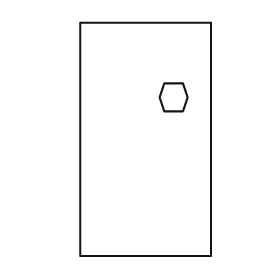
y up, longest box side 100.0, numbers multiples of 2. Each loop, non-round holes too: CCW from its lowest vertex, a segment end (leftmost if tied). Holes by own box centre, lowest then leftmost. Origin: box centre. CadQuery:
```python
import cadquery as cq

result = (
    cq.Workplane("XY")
    .moveTo(-28.0, -50.0)
    .lineTo(28.0, -50.0)
    .lineTo(28.0, 50.0)
    .lineTo(-28.0, 50.0)
    .close()
    .moveTo(8.0, 12.0)
    .lineTo(16.0, 12.0)
    .lineTo(18.0, 18.0)
    .lineTo(16.0, 24.0)
    .lineTo(8.0, 24.0)
    .lineTo(6.0, 18.0)
    .close()
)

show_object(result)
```